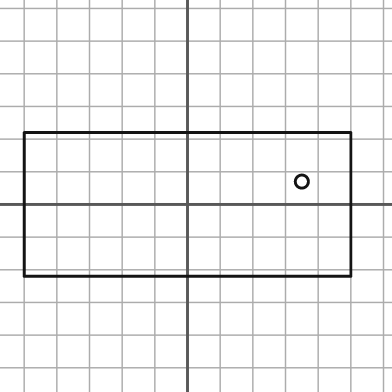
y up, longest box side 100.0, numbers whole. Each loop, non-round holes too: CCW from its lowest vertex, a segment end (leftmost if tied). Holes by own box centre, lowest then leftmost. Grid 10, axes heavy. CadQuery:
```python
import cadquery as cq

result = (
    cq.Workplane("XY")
    .moveTo(-50.0, -22.0)
    .lineTo(50.0, -22.0)
    .lineTo(50.0, 22.0)
    .lineTo(-50.0, 22.0)
    .close()
    .moveTo(35.0, 7.0)
    .circle(2.0)
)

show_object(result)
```